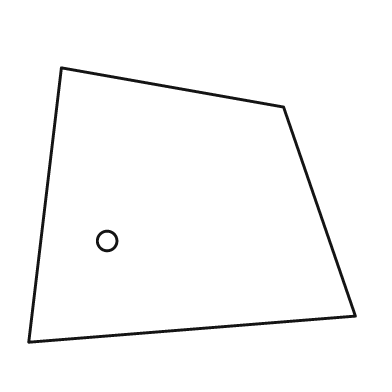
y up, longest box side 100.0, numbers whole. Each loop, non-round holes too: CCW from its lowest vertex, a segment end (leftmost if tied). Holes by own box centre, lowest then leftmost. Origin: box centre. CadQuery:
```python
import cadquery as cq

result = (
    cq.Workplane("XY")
    .moveTo(-50.0, -42.0)
    .lineTo(50.0, -34.0)
    .lineTo(28.0, 30.0)
    .lineTo(-40.0, 42.0)
    .close()
    .moveTo(-26.0, -11.0)
    .circle(3.0)
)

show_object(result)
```